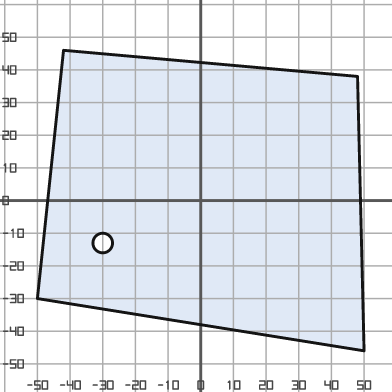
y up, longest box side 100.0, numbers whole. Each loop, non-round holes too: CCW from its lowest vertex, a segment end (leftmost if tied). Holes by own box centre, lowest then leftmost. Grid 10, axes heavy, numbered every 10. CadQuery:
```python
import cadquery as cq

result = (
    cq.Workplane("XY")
    .moveTo(50.0, -46.0)
    .lineTo(48.0, 38.0)
    .lineTo(-42.0, 46.0)
    .lineTo(-50.0, -30.0)
    .close()
    .moveTo(-30.0, -13.0)
    .circle(3.0)
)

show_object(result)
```